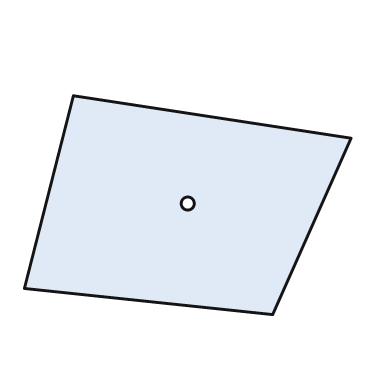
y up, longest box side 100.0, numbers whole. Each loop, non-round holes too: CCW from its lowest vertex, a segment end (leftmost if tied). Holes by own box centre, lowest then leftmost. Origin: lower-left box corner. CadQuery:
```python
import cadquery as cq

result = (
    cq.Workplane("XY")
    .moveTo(76.0, 0.0)
    .lineTo(100.0, 54.0)
    .lineTo(15.0, 67.0)
    .lineTo(0.0, 8.0)
    .close()
    .moveTo(50.0, 34.0)
    .circle(2.0)
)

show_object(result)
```